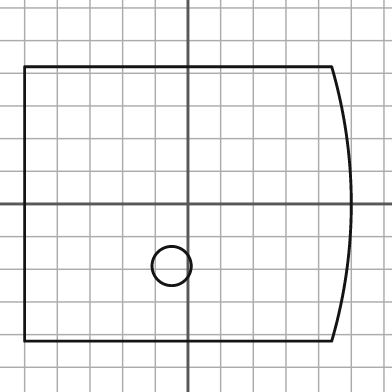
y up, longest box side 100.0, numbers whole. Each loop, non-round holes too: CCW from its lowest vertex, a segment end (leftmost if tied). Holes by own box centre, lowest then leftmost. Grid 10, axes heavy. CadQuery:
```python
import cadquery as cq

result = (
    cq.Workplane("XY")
    .moveTo(-50.0, -42.0)
    .lineTo(44.0, -42.0)
    .threePointArc((50.0, 0.0), (44.0, 42.0))
    .lineTo(-50.0, 42.0)
    .close()
    .moveTo(-5.0, -19.0)
    .circle(6.0)
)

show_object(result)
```